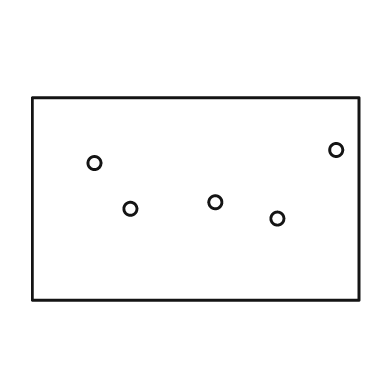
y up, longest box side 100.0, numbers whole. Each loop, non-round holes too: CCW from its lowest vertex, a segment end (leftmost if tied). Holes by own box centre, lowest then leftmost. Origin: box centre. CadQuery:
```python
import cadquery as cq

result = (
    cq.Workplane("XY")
    .moveTo(-50.0, -31.0)
    .lineTo(50.0, -31.0)
    .lineTo(50.0, 31.0)
    .lineTo(-50.0, 31.0)
    .close()
    .moveTo(25.0, -6.0)
    .circle(2.0)
    .moveTo(-20.0, -3.0)
    .circle(2.0)
    .moveTo(6.0, -1.0)
    .circle(2.0)
    .moveTo(-31.0, 11.0)
    .circle(2.0)
    .moveTo(43.0, 15.0)
    .circle(2.0)
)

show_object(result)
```